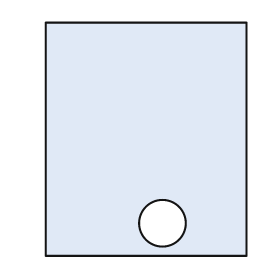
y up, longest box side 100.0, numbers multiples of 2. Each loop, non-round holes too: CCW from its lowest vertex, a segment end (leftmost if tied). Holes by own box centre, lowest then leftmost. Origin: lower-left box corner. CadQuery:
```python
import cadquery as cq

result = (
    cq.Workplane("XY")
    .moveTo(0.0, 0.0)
    .lineTo(86.0, 0.0)
    .lineTo(86.0, 100.0)
    .lineTo(0.0, 100.0)
    .close()
    .moveTo(50.0, 14.0)
    .circle(10.0)
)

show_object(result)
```